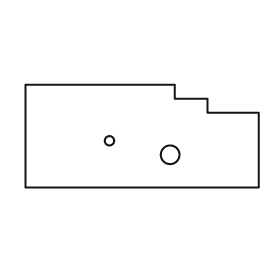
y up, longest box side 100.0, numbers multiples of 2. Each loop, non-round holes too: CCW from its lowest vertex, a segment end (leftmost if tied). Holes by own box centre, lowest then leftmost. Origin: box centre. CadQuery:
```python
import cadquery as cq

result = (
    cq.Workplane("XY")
    .moveTo(-50.0, -22.0)
    .lineTo(50.0, -22.0)
    .lineTo(50.0, 10.0)
    .lineTo(28.0, 10.0)
    .lineTo(28.0, 16.0)
    .lineTo(14.0, 16.0)
    .lineTo(14.0, 22.0)
    .lineTo(-50.0, 22.0)
    .close()
    .moveTo(12.0, -8.0)
    .circle(4.0)
    .moveTo(-14.0, -2.0)
    .circle(2.0)
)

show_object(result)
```